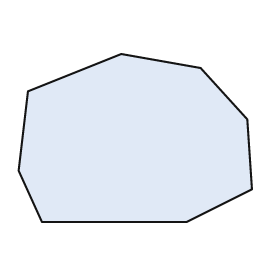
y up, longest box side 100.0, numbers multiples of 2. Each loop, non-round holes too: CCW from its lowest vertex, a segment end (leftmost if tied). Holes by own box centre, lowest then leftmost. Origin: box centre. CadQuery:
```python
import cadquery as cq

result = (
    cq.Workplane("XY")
    .moveTo(-40.0, -36.0)
    .lineTo(22.0, -36.0)
    .lineTo(50.0, -22.0)
    .lineTo(48.0, 8.0)
    .lineTo(28.0, 30.0)
    .lineTo(-6.0, 36.0)
    .lineTo(-46.0, 20.0)
    .lineTo(-50.0, -14.0)
    .close()
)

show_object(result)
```